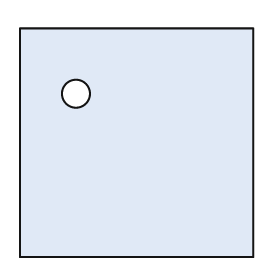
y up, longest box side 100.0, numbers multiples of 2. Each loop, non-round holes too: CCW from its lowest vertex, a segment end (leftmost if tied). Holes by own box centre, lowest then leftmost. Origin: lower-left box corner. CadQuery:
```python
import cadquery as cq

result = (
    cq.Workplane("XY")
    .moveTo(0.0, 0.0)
    .lineTo(100.0, 0.0)
    .lineTo(100.0, 98.0)
    .lineTo(0.0, 98.0)
    .close()
    .moveTo(24.0, 70.0)
    .circle(6.0)
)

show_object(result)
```